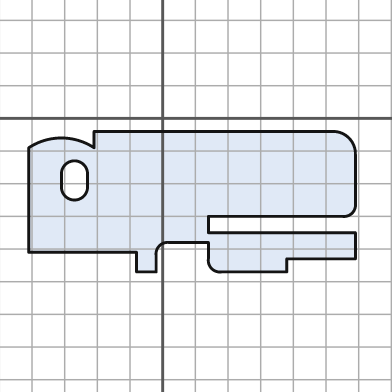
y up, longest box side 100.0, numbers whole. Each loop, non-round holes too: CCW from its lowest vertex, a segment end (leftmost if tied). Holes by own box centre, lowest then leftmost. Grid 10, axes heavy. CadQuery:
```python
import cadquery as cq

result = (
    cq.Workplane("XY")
    .moveTo(-8.0, -47.0)
    .lineTo(-2.0, -47.0)
    .lineTo(-2.0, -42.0)
    .threePointArc((-1.0, -39.0), (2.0, -38.0))
    .lineTo(14.0, -38.0)
    .lineTo(14.0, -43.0)
    .threePointArc((15.0, -46.0), (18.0, -47.0))
    .lineTo(38.0, -47.0)
    .lineTo(38.0, -43.0)
    .lineTo(59.0, -43.0)
    .lineTo(59.0, -35.0)
    .lineTo(14.0, -35.0)
    .lineTo(14.0, -30.0)
    .lineTo(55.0, -30.0)
    .threePointArc((58.0, -29.0), (59.0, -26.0))
    .lineTo(59.0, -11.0)
    .threePointArc((57.0, -6.0), (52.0, -4.0))
    .lineTo(-21.0, -4.0)
    .lineTo(-21.0, -9.0)
    .threePointArc((-31.0, -6.0), (-41.0, -9.0))
    .lineTo(-41.0, -41.0)
    .lineTo(-8.0, -41.0)
    .close()
    .moveTo(-31.0, -21.0)
    .threePointArc((-27.0, -25.0), (-23.0, -21.0))
    .lineTo(-23.0, -17.0)
    .threePointArc((-27.0, -13.0), (-31.0, -17.0))
    .close()
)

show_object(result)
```